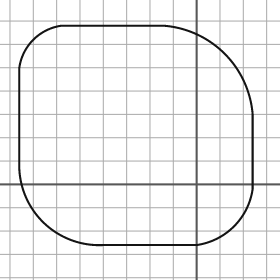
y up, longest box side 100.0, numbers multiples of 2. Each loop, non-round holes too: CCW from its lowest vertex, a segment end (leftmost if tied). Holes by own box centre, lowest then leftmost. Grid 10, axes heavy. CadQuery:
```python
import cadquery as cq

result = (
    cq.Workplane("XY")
    .moveTo(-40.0, -26.0)
    .lineTo(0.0, -26.0)
    .threePointArc((16.0, -18.0), (24.0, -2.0))
    .lineTo(24.0, 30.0)
    .threePointArc((12.0, 56.0), (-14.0, 68.0))
    .lineTo(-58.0, 68.0)
    .threePointArc((-70.0, 62.0), (-76.0, 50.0))
    .lineTo(-76.0, 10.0)
    .threePointArc((-66.0, -16.0), (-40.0, -26.0))
    .close()
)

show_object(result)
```